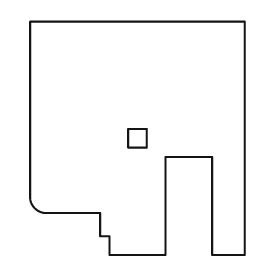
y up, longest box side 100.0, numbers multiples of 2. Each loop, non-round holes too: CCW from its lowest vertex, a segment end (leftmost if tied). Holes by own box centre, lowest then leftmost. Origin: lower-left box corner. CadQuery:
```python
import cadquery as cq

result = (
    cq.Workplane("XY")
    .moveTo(34.0, 0.0)
    .lineTo(58.0, 0.0)
    .lineTo(58.0, 42.0)
    .lineTo(78.0, 42.0)
    .lineTo(78.0, 0.0)
    .lineTo(92.0, 0.0)
    .lineTo(92.0, 100.0)
    .lineTo(0.0, 100.0)
    .lineTo(0.0, 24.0)
    .threePointArc((2.0, 20.0), (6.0, 18.0))
    .lineTo(30.0, 18.0)
    .lineTo(30.0, 8.0)
    .lineTo(34.0, 8.0)
    .close()
    .moveTo(42.0, 46.0)
    .lineTo(50.0, 46.0)
    .lineTo(50.0, 54.0)
    .lineTo(42.0, 54.0)
    .close()
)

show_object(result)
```